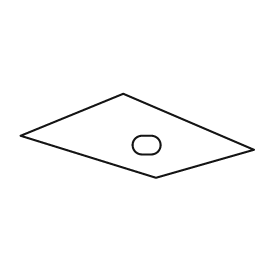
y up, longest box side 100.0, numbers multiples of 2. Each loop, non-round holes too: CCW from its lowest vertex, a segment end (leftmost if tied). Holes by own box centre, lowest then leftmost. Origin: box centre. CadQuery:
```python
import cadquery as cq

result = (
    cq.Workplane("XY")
    .moveTo(8.0, -18.0)
    .lineTo(50.0, -6.0)
    .lineTo(-6.0, 18.0)
    .lineTo(-50.0, 0.0)
    .close()
    .moveTo(2.0, -8.0)
    .lineTo(6.0, -8.0)
    .threePointArc((10.0, -4.0), (6.0, 0.0))
    .lineTo(2.0, 0.0)
    .threePointArc((-2.0, -4.0), (2.0, -8.0))
    .close()
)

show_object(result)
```